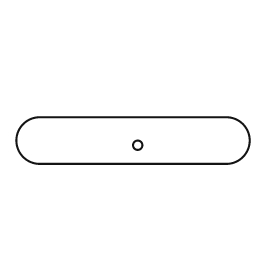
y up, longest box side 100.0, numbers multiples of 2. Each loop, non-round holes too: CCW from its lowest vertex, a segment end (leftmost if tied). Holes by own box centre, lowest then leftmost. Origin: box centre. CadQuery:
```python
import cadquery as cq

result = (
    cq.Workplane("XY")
    .moveTo(-40.0, -10.0)
    .lineTo(40.0, -10.0)
    .threePointArc((50.0, 0.0), (40.0, 10.0))
    .lineTo(-40.0, 10.0)
    .threePointArc((-50.0, 0.0), (-40.0, -10.0))
    .close()
    .moveTo(2.0, -2.0)
    .circle(2.0)
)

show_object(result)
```